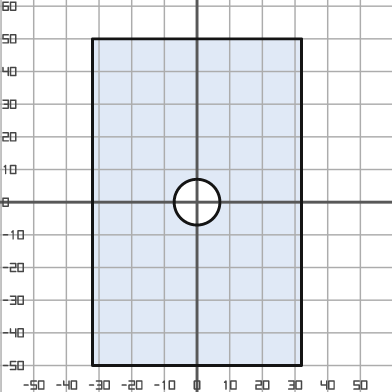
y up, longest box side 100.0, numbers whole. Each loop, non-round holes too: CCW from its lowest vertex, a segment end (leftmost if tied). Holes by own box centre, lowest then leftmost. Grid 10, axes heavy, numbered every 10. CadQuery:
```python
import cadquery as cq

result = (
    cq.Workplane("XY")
    .moveTo(-32.0, -50.0)
    .lineTo(32.0, -50.0)
    .lineTo(32.0, 50.0)
    .lineTo(-32.0, 50.0)
    .close()
    .moveTo(0.0, 0.0)
    .circle(7.0)
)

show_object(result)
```